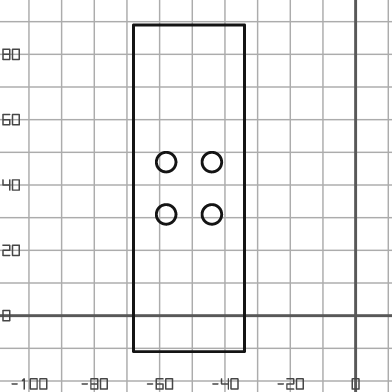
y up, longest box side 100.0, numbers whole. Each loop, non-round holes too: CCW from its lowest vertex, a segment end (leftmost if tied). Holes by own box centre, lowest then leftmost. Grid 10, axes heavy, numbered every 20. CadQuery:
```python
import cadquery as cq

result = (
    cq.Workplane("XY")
    .moveTo(-68.0, -11.0)
    .lineTo(-34.0, -11.0)
    .lineTo(-34.0, 89.0)
    .lineTo(-68.0, 89.0)
    .close()
    .moveTo(-58.0, 31.0)
    .circle(3.0)
    .moveTo(-44.0, 31.0)
    .circle(3.0)
    .moveTo(-58.0, 47.0)
    .circle(3.0)
    .moveTo(-44.0, 47.0)
    .circle(3.0)
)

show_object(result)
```